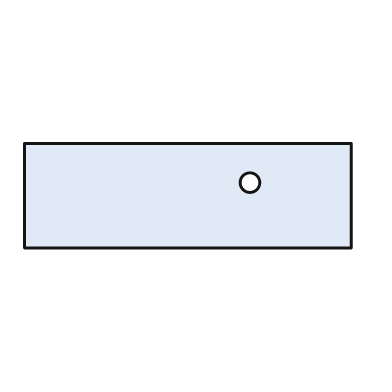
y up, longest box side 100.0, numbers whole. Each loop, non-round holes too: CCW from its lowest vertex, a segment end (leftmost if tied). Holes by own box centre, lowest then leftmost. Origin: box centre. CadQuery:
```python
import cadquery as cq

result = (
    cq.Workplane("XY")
    .moveTo(-50.0, -16.0)
    .lineTo(50.0, -16.0)
    .lineTo(50.0, 16.0)
    .lineTo(-50.0, 16.0)
    .close()
    .moveTo(19.0, 4.0)
    .circle(3.0)
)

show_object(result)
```